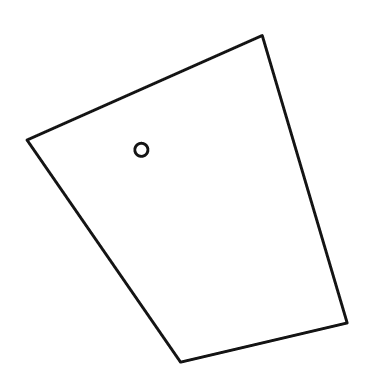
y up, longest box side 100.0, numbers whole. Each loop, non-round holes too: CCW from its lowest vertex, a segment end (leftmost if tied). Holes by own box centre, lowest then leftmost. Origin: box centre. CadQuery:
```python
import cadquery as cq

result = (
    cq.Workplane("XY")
    .moveTo(-2.0, -50.0)
    .lineTo(49.0, -38.0)
    .lineTo(23.0, 50.0)
    .lineTo(-49.0, 18.0)
    .close()
    .moveTo(-14.0, 15.0)
    .circle(2.0)
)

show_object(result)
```